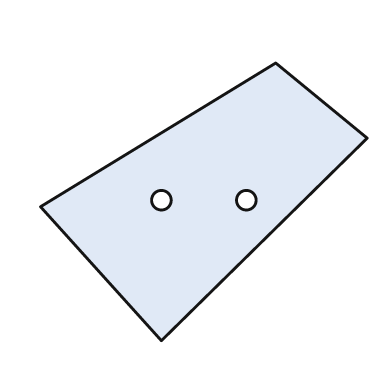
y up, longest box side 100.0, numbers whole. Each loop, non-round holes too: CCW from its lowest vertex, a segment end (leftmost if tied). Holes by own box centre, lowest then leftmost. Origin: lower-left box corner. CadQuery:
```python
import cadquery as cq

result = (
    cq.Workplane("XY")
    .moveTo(37.0, 0.0)
    .lineTo(100.0, 62.0)
    .lineTo(72.0, 85.0)
    .lineTo(0.0, 41.0)
    .close()
    .moveTo(37.0, 43.0)
    .circle(3.0)
    .moveTo(63.0, 43.0)
    .circle(3.0)
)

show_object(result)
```